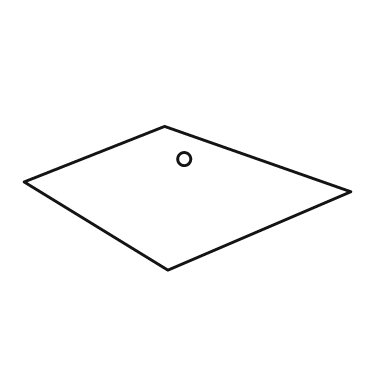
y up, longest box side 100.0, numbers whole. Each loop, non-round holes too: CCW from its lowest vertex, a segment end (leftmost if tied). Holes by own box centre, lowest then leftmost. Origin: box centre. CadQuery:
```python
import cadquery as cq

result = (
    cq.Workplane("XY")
    .moveTo(-6.0, -22.0)
    .lineTo(50.0, 2.0)
    .lineTo(-7.0, 22.0)
    .lineTo(-50.0, 5.0)
    .close()
    .moveTo(-1.0, 12.0)
    .circle(2.0)
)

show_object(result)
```